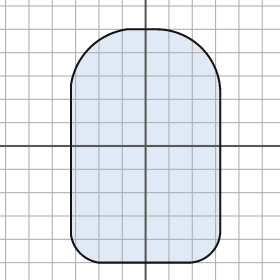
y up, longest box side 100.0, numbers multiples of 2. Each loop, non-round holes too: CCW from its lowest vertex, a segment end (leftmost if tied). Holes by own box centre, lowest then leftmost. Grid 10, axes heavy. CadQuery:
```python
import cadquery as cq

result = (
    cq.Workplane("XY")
    .moveTo(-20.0, -50.0)
    .lineTo(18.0, -50.0)
    .threePointArc((28.0, -46.0), (32.0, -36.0))
    .lineTo(32.0, 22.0)
    .threePointArc((24.0, 42.0), (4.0, 50.0))
    .lineTo(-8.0, 50.0)
    .threePointArc((-24.0, 42.0), (-32.0, 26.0))
    .lineTo(-32.0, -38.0)
    .threePointArc((-28.0, -46.0), (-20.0, -50.0))
    .close()
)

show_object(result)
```